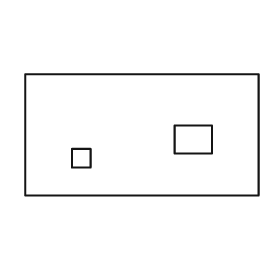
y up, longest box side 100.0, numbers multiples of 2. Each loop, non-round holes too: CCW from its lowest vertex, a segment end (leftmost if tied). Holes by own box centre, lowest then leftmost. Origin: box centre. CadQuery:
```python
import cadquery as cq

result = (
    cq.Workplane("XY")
    .moveTo(-50.0, -26.0)
    .lineTo(50.0, -26.0)
    .lineTo(50.0, 26.0)
    .lineTo(-50.0, 26.0)
    .close()
    .moveTo(-30.0, -14.0)
    .lineTo(-22.0, -14.0)
    .lineTo(-22.0, -6.0)
    .lineTo(-30.0, -6.0)
    .close()
    .moveTo(14.0, -8.0)
    .lineTo(30.0, -8.0)
    .lineTo(30.0, 4.0)
    .lineTo(14.0, 4.0)
    .close()
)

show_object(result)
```